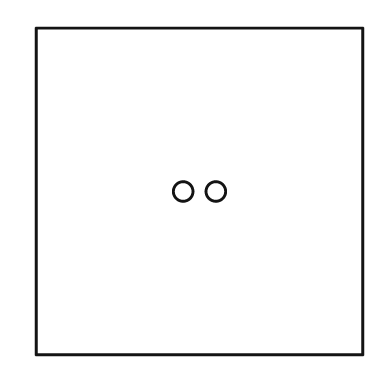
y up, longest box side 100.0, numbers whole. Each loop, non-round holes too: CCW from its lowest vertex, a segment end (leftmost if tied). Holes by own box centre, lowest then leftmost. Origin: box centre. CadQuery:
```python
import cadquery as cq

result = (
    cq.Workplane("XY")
    .moveTo(-50.0, -50.0)
    .lineTo(50.0, -50.0)
    .lineTo(50.0, 50.0)
    .lineTo(-50.0, 50.0)
    .close()
    .moveTo(-5.0, 0.0)
    .circle(3.0)
    .moveTo(5.0, 0.0)
    .circle(3.0)
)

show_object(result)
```